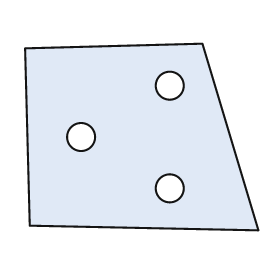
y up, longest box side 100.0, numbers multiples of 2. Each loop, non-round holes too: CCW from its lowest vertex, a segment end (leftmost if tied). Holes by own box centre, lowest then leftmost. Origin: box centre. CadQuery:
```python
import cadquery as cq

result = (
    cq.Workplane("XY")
    .moveTo(50.0, -40.0)
    .lineTo(26.0, 40.0)
    .lineTo(-50.0, 38.0)
    .lineTo(-48.0, -38.0)
    .close()
    .moveTo(12.0, -22.0)
    .circle(6.0)
    .moveTo(-26.0, 0.0)
    .circle(6.0)
    .moveTo(12.0, 22.0)
    .circle(6.0)
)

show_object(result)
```